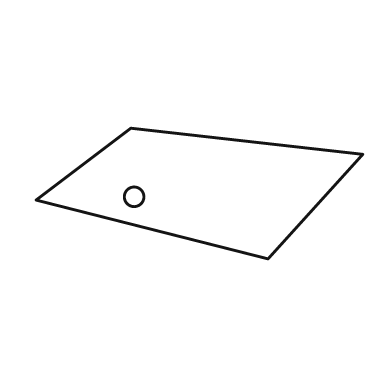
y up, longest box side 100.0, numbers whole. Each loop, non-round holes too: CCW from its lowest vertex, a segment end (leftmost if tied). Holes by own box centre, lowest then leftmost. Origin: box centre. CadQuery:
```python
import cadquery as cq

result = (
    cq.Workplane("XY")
    .moveTo(21.0, -20.0)
    .lineTo(50.0, 12.0)
    .lineTo(-21.0, 20.0)
    .lineTo(-50.0, -2.0)
    .close()
    .moveTo(-20.0, -1.0)
    .circle(3.0)
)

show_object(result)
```